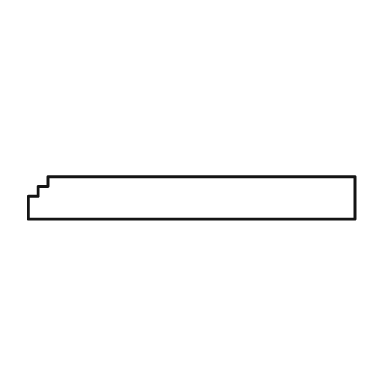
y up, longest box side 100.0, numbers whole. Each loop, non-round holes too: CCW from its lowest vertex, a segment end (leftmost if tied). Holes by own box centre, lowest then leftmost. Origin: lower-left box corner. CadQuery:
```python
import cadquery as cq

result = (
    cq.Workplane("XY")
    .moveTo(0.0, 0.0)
    .lineTo(100.0, 0.0)
    .lineTo(100.0, 13.0)
    .lineTo(6.0, 13.0)
    .lineTo(6.0, 10.0)
    .lineTo(3.0, 10.0)
    .lineTo(3.0, 7.0)
    .lineTo(0.0, 7.0)
    .close()
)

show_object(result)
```